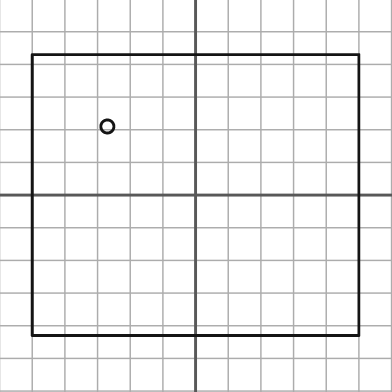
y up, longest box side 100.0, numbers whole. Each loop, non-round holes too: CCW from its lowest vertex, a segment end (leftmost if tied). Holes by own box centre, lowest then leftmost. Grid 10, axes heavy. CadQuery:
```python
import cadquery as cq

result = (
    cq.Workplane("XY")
    .moveTo(-50.0, -43.0)
    .lineTo(50.0, -43.0)
    .lineTo(50.0, 43.0)
    .lineTo(-50.0, 43.0)
    .close()
    .moveTo(-27.0, 21.0)
    .circle(2.0)
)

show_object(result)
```